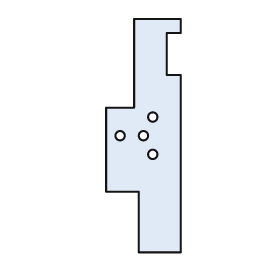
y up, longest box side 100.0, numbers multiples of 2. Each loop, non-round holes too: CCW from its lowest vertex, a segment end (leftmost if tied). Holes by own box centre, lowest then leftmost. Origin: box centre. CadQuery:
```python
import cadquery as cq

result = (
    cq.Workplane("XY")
    .moveTo(-2.0, -50.0)
    .lineTo(16.0, -50.0)
    .lineTo(16.0, 26.0)
    .lineTo(10.0, 26.0)
    .lineTo(10.0, 44.0)
    .lineTo(16.0, 44.0)
    .lineTo(16.0, 50.0)
    .lineTo(-4.0, 50.0)
    .lineTo(-4.0, 12.0)
    .lineTo(-16.0, 12.0)
    .lineTo(-16.0, -24.0)
    .lineTo(-2.0, -24.0)
    .close()
    .moveTo(4.0, -8.0)
    .circle(2.0)
    .moveTo(-10.0, 0.0)
    .circle(2.0)
    .moveTo(0.0, 0.0)
    .circle(2.0)
    .moveTo(4.0, 8.0)
    .circle(2.0)
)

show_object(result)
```